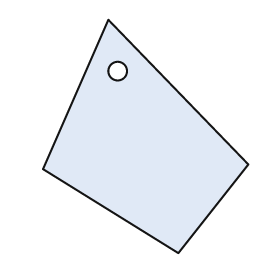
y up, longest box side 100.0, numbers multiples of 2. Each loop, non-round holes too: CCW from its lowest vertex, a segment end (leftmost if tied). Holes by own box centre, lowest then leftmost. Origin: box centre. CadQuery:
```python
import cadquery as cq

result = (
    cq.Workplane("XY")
    .moveTo(14.0, -50.0)
    .lineTo(44.0, -12.0)
    .lineTo(-16.0, 50.0)
    .lineTo(-44.0, -14.0)
    .close()
    .moveTo(-12.0, 28.0)
    .circle(4.0)
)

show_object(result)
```